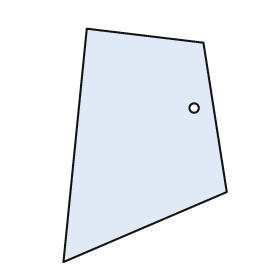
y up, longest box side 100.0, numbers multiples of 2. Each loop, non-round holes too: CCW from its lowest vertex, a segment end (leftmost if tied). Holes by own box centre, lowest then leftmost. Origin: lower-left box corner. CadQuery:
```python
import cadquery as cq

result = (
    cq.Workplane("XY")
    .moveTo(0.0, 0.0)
    .lineTo(70.0, 30.0)
    .lineTo(60.0, 94.0)
    .lineTo(10.0, 100.0)
    .close()
    .moveTo(56.0, 66.0)
    .circle(2.0)
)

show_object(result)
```